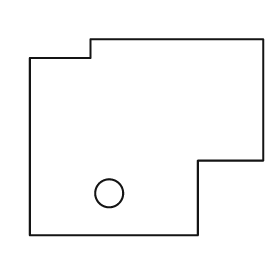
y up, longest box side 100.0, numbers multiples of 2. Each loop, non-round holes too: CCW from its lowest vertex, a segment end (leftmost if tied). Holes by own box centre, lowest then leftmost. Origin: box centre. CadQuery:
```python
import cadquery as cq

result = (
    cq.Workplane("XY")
    .moveTo(-50.0, -42.0)
    .lineTo(22.0, -42.0)
    .lineTo(22.0, -10.0)
    .lineTo(50.0, -10.0)
    .lineTo(50.0, 42.0)
    .lineTo(-24.0, 42.0)
    .lineTo(-24.0, 34.0)
    .lineTo(-50.0, 34.0)
    .close()
    .moveTo(-16.0, -24.0)
    .circle(6.0)
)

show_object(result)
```